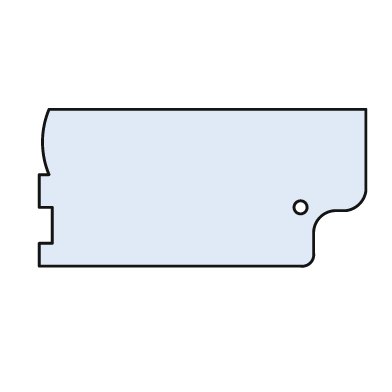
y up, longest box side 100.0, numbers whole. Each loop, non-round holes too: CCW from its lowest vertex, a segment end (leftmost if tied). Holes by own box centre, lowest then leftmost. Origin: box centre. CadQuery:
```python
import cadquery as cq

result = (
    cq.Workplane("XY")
    .moveTo(-50.0, -24.0)
    .lineTo(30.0, -24.0)
    .threePointArc((33.0, -23.0), (34.0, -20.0))
    .lineTo(34.0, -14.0)
    .threePointArc((36.0, -9.0), (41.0, -7.0))
    .lineTo(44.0, -7.0)
    .threePointArc((48.0, -5.0), (50.0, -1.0))
    .lineTo(50.0, 24.0)
    .lineTo(-47.0, 24.0)
    .threePointArc((-49.0, 14.0), (-47.0, 4.0))
    .lineTo(-50.0, 4.0)
    .lineTo(-50.0, -6.0)
    .lineTo(-46.0, -6.0)
    .lineTo(-46.0, -17.0)
    .lineTo(-50.0, -17.0)
    .close()
    .moveTo(30.0, -6.0)
    .circle(2.0)
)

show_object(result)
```